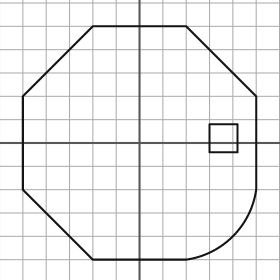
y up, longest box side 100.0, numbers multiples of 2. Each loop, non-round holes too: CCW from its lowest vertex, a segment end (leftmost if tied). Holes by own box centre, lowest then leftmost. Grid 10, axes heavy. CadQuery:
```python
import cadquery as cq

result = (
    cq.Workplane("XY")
    .moveTo(-20.0, -50.0)
    .lineTo(20.0, -50.0)
    .threePointArc((40.0, -40.0), (50.0, -20.0))
    .lineTo(50.0, 20.0)
    .lineTo(20.0, 50.0)
    .lineTo(-20.0, 50.0)
    .lineTo(-50.0, 20.0)
    .lineTo(-50.0, -20.0)
    .close()
    .moveTo(30.0, -4.0)
    .lineTo(42.0, -4.0)
    .lineTo(42.0, 8.0)
    .lineTo(30.0, 8.0)
    .close()
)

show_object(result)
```